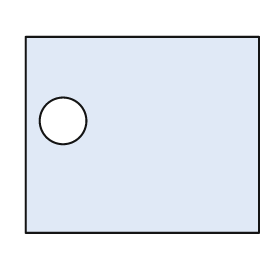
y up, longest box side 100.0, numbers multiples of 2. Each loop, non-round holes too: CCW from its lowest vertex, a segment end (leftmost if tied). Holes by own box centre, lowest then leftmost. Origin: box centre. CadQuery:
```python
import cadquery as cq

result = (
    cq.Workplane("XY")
    .moveTo(-50.0, -42.0)
    .lineTo(50.0, -42.0)
    .lineTo(50.0, 42.0)
    .lineTo(-50.0, 42.0)
    .close()
    .moveTo(-34.0, 6.0)
    .circle(10.0)
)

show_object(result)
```